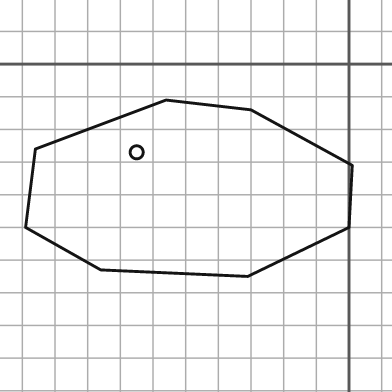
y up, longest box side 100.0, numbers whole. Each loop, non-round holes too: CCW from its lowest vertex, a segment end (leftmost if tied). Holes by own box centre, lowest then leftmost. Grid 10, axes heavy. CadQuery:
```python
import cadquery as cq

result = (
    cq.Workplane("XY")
    .moveTo(-31.0, -65.0)
    .lineTo(0.0, -50.0)
    .lineTo(1.0, -31.0)
    .lineTo(-30.0, -14.0)
    .lineTo(-56.0, -11.0)
    .lineTo(-96.0, -26.0)
    .lineTo(-99.0, -50.0)
    .lineTo(-76.0, -63.0)
    .close()
    .moveTo(-65.0, -27.0)
    .circle(2.0)
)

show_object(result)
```